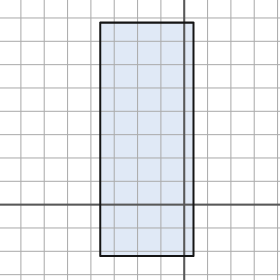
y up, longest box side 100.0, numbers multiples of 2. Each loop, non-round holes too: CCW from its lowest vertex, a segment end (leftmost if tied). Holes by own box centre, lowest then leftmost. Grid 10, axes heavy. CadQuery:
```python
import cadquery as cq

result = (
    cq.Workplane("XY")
    .moveTo(-36.0, -22.0)
    .lineTo(4.0, -22.0)
    .lineTo(4.0, 78.0)
    .lineTo(-36.0, 78.0)
    .close()
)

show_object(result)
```